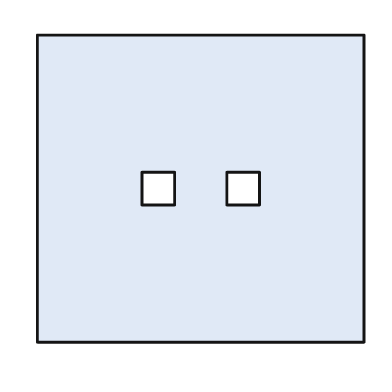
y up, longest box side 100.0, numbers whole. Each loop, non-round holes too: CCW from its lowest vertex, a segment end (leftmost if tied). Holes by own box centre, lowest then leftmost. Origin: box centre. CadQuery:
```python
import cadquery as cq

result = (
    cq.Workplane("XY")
    .moveTo(-50.0, -47.0)
    .lineTo(50.0, -47.0)
    .lineTo(50.0, 47.0)
    .lineTo(-50.0, 47.0)
    .close()
    .moveTo(-18.0, -5.0)
    .lineTo(-8.0, -5.0)
    .lineTo(-8.0, 5.0)
    .lineTo(-18.0, 5.0)
    .close()
    .moveTo(8.0, -5.0)
    .lineTo(18.0, -5.0)
    .lineTo(18.0, 5.0)
    .lineTo(8.0, 5.0)
    .close()
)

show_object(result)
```